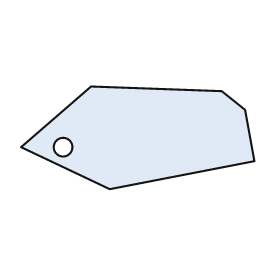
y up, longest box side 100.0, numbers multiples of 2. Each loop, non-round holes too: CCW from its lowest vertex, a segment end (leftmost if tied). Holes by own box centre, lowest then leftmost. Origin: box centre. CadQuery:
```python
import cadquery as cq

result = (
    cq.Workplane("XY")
    .moveTo(-12.0, -22.0)
    .lineTo(50.0, -10.0)
    .lineTo(46.0, 12.0)
    .lineTo(36.0, 20.0)
    .lineTo(-20.0, 22.0)
    .lineTo(-50.0, -4.0)
    .close()
    .moveTo(-32.0, -4.0)
    .circle(4.0)
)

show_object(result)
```